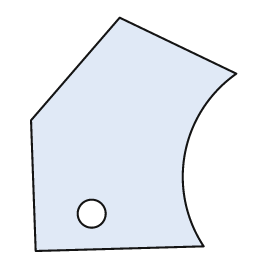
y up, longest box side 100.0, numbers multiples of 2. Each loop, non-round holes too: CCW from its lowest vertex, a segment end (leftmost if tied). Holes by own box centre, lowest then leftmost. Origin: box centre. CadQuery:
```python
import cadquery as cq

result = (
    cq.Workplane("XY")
    .moveTo(-42.0, -50.0)
    .lineTo(30.0, -48.0)
    .threePointArc((22.0, -8.0), (44.0, 26.0))
    .lineTo(-6.0, 50.0)
    .lineTo(-44.0, 6.0)
    .close()
    .moveTo(-18.0, -34.0)
    .circle(6.0)
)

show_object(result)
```